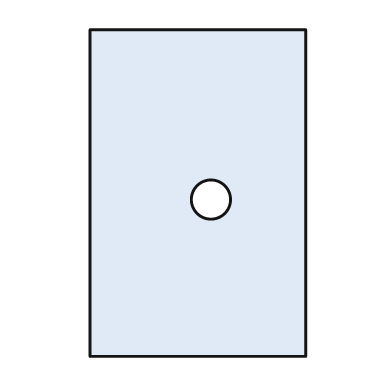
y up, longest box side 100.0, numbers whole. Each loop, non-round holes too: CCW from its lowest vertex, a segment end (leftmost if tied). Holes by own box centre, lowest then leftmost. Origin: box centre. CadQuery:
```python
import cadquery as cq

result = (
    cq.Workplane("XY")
    .moveTo(-33.0, -50.0)
    .lineTo(33.0, -50.0)
    .lineTo(33.0, 50.0)
    .lineTo(-33.0, 50.0)
    .close()
    .moveTo(4.0, -2.0)
    .circle(6.0)
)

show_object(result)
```